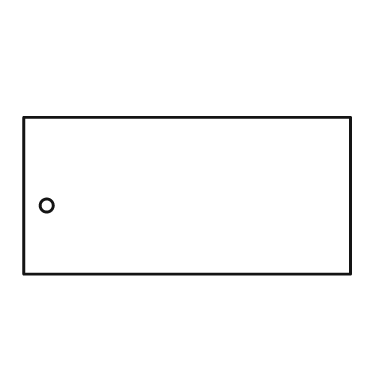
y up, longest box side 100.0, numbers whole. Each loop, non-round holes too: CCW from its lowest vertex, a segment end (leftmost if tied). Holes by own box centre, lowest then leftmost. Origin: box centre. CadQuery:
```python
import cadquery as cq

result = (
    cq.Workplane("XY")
    .moveTo(-50.0, -24.0)
    .lineTo(50.0, -24.0)
    .lineTo(50.0, 24.0)
    .lineTo(-50.0, 24.0)
    .close()
    .moveTo(-43.0, -3.0)
    .circle(2.0)
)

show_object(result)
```